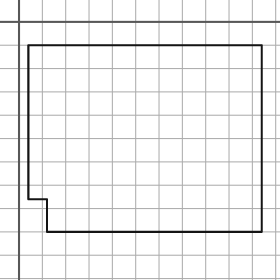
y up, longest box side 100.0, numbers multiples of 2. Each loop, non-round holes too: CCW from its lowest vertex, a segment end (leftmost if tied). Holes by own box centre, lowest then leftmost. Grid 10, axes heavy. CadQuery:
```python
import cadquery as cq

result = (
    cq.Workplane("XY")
    .moveTo(12.0, -90.0)
    .lineTo(104.0, -90.0)
    .lineTo(104.0, -10.0)
    .lineTo(4.0, -10.0)
    .lineTo(4.0, -76.0)
    .lineTo(12.0, -76.0)
    .close()
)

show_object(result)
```